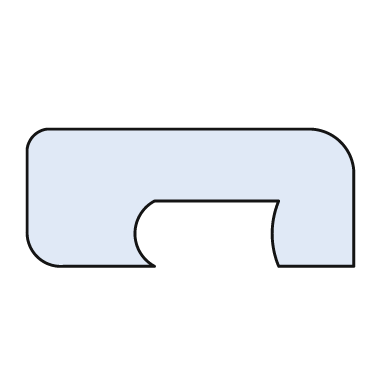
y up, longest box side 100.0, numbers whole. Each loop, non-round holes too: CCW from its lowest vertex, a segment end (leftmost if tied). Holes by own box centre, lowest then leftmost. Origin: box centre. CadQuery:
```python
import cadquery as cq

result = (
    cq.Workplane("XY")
    .moveTo(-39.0, -21.0)
    .lineTo(-11.0, -21.0)
    .threePointArc((-17.0, -11.0), (-11.0, -1.0))
    .lineTo(27.0, -1.0)
    .threePointArc((25.0, -11.0), (27.0, -21.0))
    .lineTo(50.0, -21.0)
    .lineTo(50.0, 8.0)
    .threePointArc((46.0, 17.0), (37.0, 21.0))
    .lineTo(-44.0, 21.0)
    .threePointArc((-48.0, 19.0), (-50.0, 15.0))
    .lineTo(-50.0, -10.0)
    .threePointArc((-47.0, -18.0), (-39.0, -21.0))
    .close()
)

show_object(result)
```